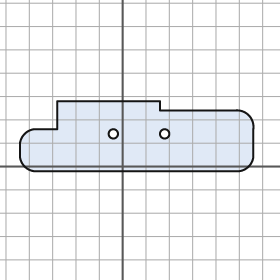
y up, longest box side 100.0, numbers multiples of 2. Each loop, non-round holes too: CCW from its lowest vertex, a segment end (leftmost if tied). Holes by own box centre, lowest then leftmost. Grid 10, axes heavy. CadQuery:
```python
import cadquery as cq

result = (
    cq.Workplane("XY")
    .moveTo(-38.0, -2.0)
    .lineTo(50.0, -2.0)
    .threePointArc((54.0, 0.0), (56.0, 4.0))
    .lineTo(56.0, 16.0)
    .threePointArc((54.0, 22.0), (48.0, 24.0))
    .lineTo(16.0, 24.0)
    .lineTo(16.0, 28.0)
    .lineTo(-28.0, 28.0)
    .lineTo(-28.0, 16.0)
    .lineTo(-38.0, 16.0)
    .threePointArc((-42.0, 14.0), (-44.0, 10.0))
    .lineTo(-44.0, 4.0)
    .threePointArc((-42.0, 0.0), (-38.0, -2.0))
    .close()
    .moveTo(-4.0, 14.0)
    .circle(2.0)
    .moveTo(18.0, 14.0)
    .circle(2.0)
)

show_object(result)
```